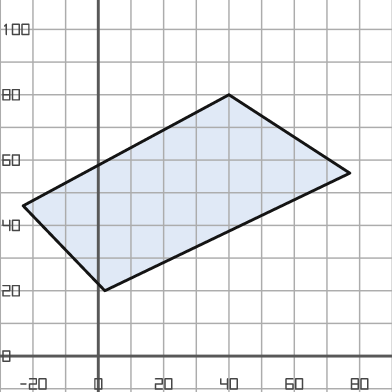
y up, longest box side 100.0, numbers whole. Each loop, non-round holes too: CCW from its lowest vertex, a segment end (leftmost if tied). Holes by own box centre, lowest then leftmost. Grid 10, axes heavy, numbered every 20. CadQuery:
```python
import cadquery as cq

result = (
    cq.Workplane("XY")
    .moveTo(2.0, 20.0)
    .lineTo(77.0, 56.0)
    .lineTo(40.0, 80.0)
    .lineTo(-23.0, 46.0)
    .close()
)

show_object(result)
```